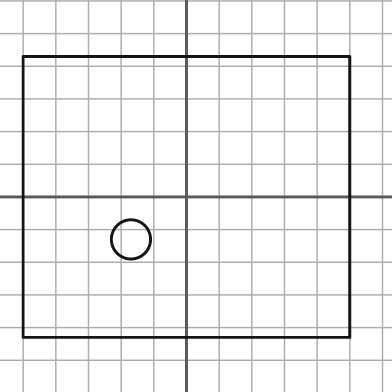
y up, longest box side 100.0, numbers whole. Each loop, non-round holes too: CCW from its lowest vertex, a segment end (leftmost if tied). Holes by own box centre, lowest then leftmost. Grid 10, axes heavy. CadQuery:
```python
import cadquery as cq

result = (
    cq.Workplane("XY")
    .moveTo(-50.0, -43.0)
    .lineTo(50.0, -43.0)
    .lineTo(50.0, 43.0)
    .lineTo(-50.0, 43.0)
    .close()
    .moveTo(-17.0, -13.0)
    .circle(6.0)
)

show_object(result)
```